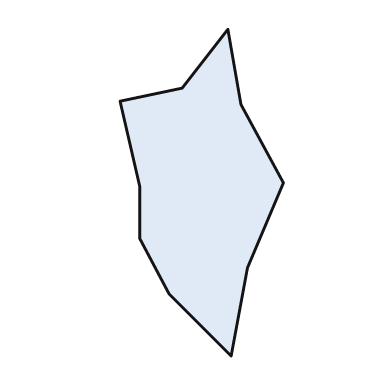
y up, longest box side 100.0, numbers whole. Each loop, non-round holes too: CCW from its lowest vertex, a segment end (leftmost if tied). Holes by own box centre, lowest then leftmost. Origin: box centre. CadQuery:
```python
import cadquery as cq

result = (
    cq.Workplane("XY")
    .moveTo(9.0, -50.0)
    .lineTo(14.0, -23.0)
    .lineTo(25.0, 3.0)
    .lineTo(12.0, 27.0)
    .lineTo(8.0, 50.0)
    .lineTo(-6.0, 32.0)
    .lineTo(-25.0, 28.0)
    .lineTo(-19.0, 2.0)
    .lineTo(-19.0, -14.0)
    .lineTo(-10.0, -31.0)
    .close()
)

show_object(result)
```